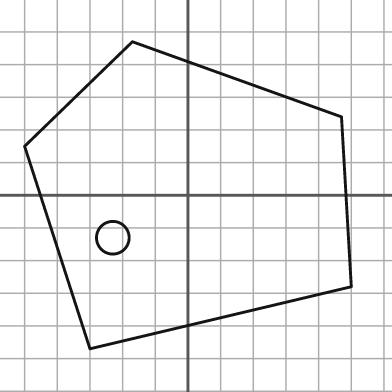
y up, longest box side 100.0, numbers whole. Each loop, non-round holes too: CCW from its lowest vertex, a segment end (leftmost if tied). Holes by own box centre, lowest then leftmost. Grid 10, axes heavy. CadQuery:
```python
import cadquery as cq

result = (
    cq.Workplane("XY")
    .moveTo(-30.0, -47.0)
    .lineTo(50.0, -28.0)
    .lineTo(47.0, 24.0)
    .lineTo(-17.0, 47.0)
    .lineTo(-50.0, 15.0)
    .close()
    .moveTo(-23.0, -13.0)
    .circle(5.0)
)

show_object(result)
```